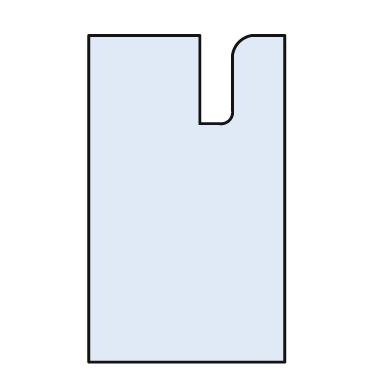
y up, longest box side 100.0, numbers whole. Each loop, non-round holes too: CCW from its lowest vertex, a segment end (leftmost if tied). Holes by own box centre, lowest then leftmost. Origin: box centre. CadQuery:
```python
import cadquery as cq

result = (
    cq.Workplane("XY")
    .moveTo(-30.0, -50.0)
    .lineTo(30.0, -50.0)
    .lineTo(30.0, 50.0)
    .lineTo(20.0, 50.0)
    .threePointArc((16.0, 48.0), (14.0, 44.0))
    .lineTo(14.0, 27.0)
    .threePointArc((13.0, 24.0), (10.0, 23.0))
    .lineTo(4.0, 23.0)
    .lineTo(4.0, 50.0)
    .lineTo(-30.0, 50.0)
    .close()
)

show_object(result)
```